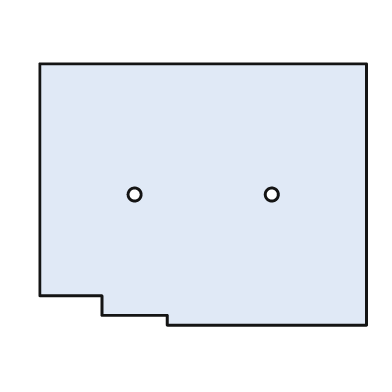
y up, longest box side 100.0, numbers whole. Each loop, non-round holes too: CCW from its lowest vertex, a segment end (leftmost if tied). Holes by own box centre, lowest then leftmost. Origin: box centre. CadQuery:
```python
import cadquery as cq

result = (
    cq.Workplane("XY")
    .moveTo(-11.0, -40.0)
    .lineTo(50.0, -40.0)
    .lineTo(50.0, 40.0)
    .lineTo(-50.0, 40.0)
    .lineTo(-50.0, -31.0)
    .lineTo(-31.0, -31.0)
    .lineTo(-31.0, -37.0)
    .lineTo(-11.0, -37.0)
    .close()
    .moveTo(-21.0, 0.0)
    .circle(2.0)
    .moveTo(21.0, 0.0)
    .circle(2.0)
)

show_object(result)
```